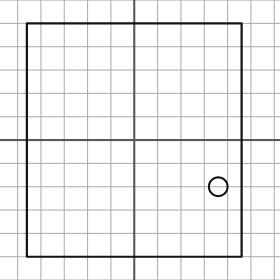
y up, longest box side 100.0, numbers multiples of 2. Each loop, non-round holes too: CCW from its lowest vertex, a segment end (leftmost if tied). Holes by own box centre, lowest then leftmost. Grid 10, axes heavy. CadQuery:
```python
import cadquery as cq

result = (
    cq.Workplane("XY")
    .moveTo(-46.0, -50.0)
    .lineTo(46.0, -50.0)
    .lineTo(46.0, 50.0)
    .lineTo(-46.0, 50.0)
    .close()
    .moveTo(36.0, -20.0)
    .circle(4.0)
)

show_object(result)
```